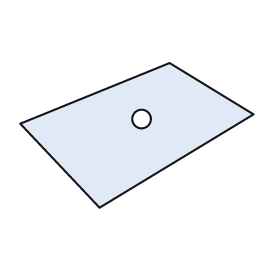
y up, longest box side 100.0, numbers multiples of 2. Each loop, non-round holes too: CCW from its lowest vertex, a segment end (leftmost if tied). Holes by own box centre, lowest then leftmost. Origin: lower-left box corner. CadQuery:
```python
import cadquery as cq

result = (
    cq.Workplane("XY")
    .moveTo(34.0, 0.0)
    .lineTo(100.0, 40.0)
    .lineTo(64.0, 62.0)
    .lineTo(0.0, 36.0)
    .close()
    .moveTo(52.0, 38.0)
    .circle(4.0)
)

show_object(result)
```